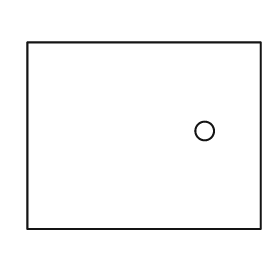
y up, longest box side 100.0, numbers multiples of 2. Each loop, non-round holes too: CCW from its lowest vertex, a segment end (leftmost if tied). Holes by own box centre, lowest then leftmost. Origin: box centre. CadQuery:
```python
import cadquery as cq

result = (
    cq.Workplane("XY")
    .moveTo(-50.0, -40.0)
    .lineTo(50.0, -40.0)
    .lineTo(50.0, 40.0)
    .lineTo(-50.0, 40.0)
    .close()
    .moveTo(26.0, 2.0)
    .circle(4.0)
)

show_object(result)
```